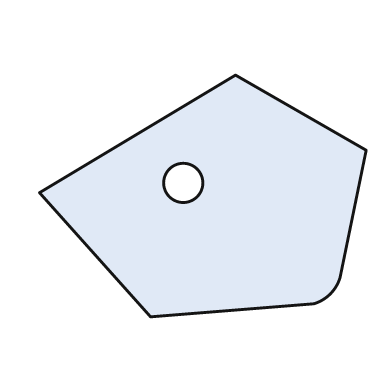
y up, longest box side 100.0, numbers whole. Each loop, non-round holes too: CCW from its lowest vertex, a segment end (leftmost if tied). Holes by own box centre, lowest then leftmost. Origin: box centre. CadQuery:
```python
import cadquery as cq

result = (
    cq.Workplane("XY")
    .moveTo(-16.0, -37.0)
    .lineTo(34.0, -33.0)
    .threePointArc((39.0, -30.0), (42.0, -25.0))
    .lineTo(50.0, 14.0)
    .lineTo(10.0, 37.0)
    .lineTo(-50.0, 1.0)
    .close()
    .moveTo(-6.0, 4.0)
    .circle(6.0)
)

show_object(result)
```